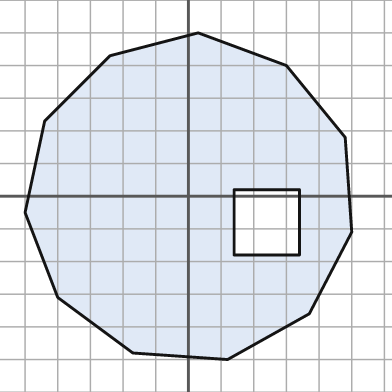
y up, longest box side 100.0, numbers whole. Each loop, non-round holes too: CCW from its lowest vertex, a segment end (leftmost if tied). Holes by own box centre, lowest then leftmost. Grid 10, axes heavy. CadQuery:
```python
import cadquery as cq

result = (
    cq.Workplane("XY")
    .moveTo(12.0, -50.0)
    .lineTo(37.0, -36.0)
    .lineTo(50.0, -11.0)
    .lineTo(48.0, 18.0)
    .lineTo(30.0, 40.0)
    .lineTo(3.0, 50.0)
    .lineTo(-24.0, 43.0)
    .lineTo(-44.0, 23.0)
    .lineTo(-50.0, -5.0)
    .lineTo(-40.0, -31.0)
    .lineTo(-17.0, -48.0)
    .close()
    .moveTo(14.0, -18.0)
    .lineTo(34.0, -18.0)
    .lineTo(34.0, 2.0)
    .lineTo(14.0, 2.0)
    .close()
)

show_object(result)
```